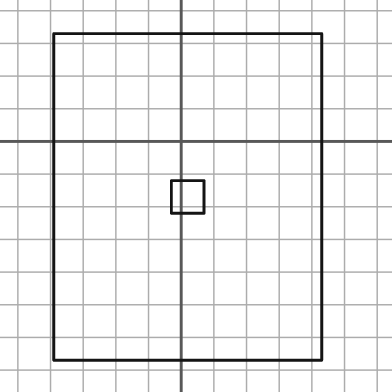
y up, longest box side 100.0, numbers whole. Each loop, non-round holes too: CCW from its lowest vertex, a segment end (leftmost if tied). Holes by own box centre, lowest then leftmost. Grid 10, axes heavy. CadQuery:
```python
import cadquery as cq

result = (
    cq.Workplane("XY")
    .moveTo(-39.0, -67.0)
    .lineTo(43.0, -67.0)
    .lineTo(43.0, 33.0)
    .lineTo(-39.0, 33.0)
    .close()
    .moveTo(-3.0, -22.0)
    .lineTo(7.0, -22.0)
    .lineTo(7.0, -12.0)
    .lineTo(-3.0, -12.0)
    .close()
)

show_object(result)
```